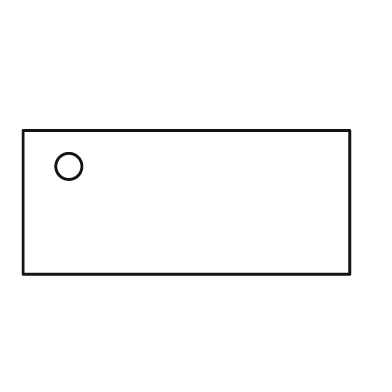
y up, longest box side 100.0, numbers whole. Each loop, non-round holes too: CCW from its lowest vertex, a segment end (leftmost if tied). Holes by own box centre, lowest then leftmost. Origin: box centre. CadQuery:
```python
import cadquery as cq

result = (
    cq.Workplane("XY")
    .moveTo(-50.0, -22.0)
    .lineTo(50.0, -22.0)
    .lineTo(50.0, 22.0)
    .lineTo(-50.0, 22.0)
    .close()
    .moveTo(-36.0, 11.0)
    .circle(4.0)
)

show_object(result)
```